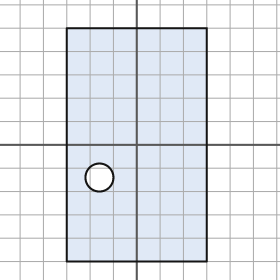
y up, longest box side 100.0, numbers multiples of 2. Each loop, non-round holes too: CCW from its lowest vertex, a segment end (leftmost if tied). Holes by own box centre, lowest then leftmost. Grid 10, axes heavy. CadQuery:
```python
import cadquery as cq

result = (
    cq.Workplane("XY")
    .moveTo(-30.0, -50.0)
    .lineTo(30.0, -50.0)
    .lineTo(30.0, 50.0)
    .lineTo(-30.0, 50.0)
    .close()
    .moveTo(-16.0, -14.0)
    .circle(6.0)
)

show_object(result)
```